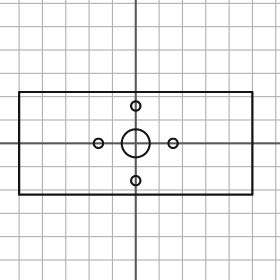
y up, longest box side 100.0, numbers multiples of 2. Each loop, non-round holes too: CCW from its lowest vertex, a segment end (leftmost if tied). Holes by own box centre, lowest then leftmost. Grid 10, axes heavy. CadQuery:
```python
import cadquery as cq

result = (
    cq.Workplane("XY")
    .moveTo(-50.0, -22.0)
    .lineTo(50.0, -22.0)
    .lineTo(50.0, 22.0)
    .lineTo(-50.0, 22.0)
    .close()
    .moveTo(0.0, -16.0)
    .circle(2.0)
    .moveTo(-16.0, 0.0)
    .circle(2.0)
    .moveTo(0.0, 0.0)
    .circle(6.0)
    .moveTo(16.0, 0.0)
    .circle(2.0)
    .moveTo(0.0, 16.0)
    .circle(2.0)
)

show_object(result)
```